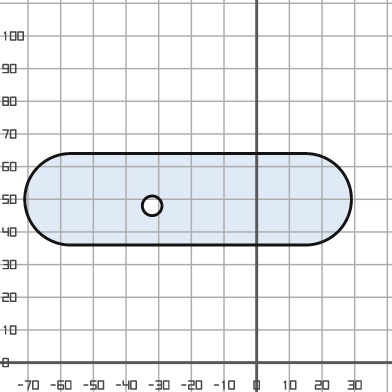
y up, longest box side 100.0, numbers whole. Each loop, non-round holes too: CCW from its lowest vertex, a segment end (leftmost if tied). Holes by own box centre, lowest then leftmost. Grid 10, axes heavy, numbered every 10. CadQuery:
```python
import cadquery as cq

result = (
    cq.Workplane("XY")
    .moveTo(-57.0, 36.0)
    .lineTo(15.0, 36.0)
    .threePointArc((29.0, 50.0), (15.0, 64.0))
    .lineTo(-57.0, 64.0)
    .threePointArc((-71.0, 50.0), (-57.0, 36.0))
    .close()
    .moveTo(-32.0, 48.0)
    .circle(3.0)
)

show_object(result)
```